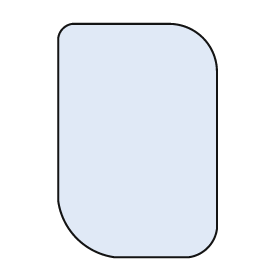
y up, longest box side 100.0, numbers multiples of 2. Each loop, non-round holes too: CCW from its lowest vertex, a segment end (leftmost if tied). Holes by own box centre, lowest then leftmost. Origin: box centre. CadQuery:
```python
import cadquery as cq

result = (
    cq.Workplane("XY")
    .moveTo(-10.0, -50.0)
    .lineTo(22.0, -50.0)
    .threePointArc((30.0, -46.0), (34.0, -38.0))
    .lineTo(34.0, 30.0)
    .threePointArc((28.0, 44.0), (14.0, 50.0))
    .lineTo(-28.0, 50.0)
    .threePointArc((-32.0, 48.0), (-34.0, 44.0))
    .lineTo(-34.0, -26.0)
    .threePointArc((-26.0, -42.0), (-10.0, -50.0))
    .close()
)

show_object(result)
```